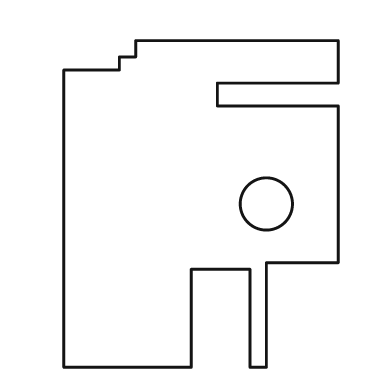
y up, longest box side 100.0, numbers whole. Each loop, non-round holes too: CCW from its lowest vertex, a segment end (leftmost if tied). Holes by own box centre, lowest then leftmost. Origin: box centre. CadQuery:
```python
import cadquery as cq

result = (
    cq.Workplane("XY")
    .moveTo(-42.0, -50.0)
    .lineTo(-3.0, -50.0)
    .lineTo(-3.0, -20.0)
    .lineTo(15.0, -20.0)
    .lineTo(15.0, -50.0)
    .lineTo(20.0, -50.0)
    .lineTo(20.0, -18.0)
    .lineTo(42.0, -18.0)
    .lineTo(42.0, 30.0)
    .lineTo(5.0, 30.0)
    .lineTo(5.0, 37.0)
    .lineTo(42.0, 37.0)
    .lineTo(42.0, 50.0)
    .lineTo(-20.0, 50.0)
    .lineTo(-20.0, 45.0)
    .lineTo(-25.0, 45.0)
    .lineTo(-25.0, 41.0)
    .lineTo(-42.0, 41.0)
    .close()
    .moveTo(20.0, 0.0)
    .circle(8.0)
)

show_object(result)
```